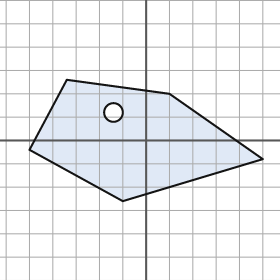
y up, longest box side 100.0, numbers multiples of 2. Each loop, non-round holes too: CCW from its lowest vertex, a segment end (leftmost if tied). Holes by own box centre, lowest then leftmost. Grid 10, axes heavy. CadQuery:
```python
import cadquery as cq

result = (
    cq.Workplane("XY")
    .moveTo(-10.0, -26.0)
    .lineTo(50.0, -8.0)
    .lineTo(10.0, 20.0)
    .lineTo(-34.0, 26.0)
    .lineTo(-50.0, -4.0)
    .close()
    .moveTo(-14.0, 12.0)
    .circle(4.0)
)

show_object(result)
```